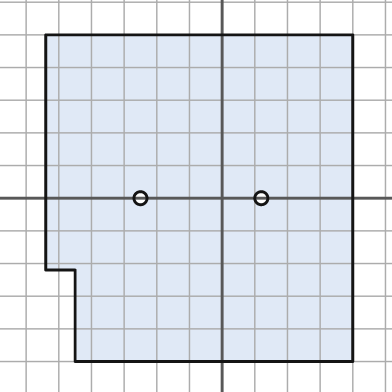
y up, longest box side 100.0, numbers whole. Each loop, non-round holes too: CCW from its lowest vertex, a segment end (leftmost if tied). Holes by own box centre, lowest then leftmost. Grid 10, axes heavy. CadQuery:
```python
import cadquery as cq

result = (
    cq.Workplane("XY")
    .moveTo(-45.0, -50.0)
    .lineTo(40.0, -50.0)
    .lineTo(40.0, 50.0)
    .lineTo(-54.0, 50.0)
    .lineTo(-54.0, -22.0)
    .lineTo(-45.0, -22.0)
    .close()
    .moveTo(-25.0, 0.0)
    .circle(2.0)
    .moveTo(12.0, 0.0)
    .circle(2.0)
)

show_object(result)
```